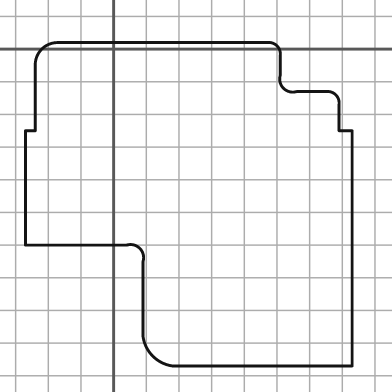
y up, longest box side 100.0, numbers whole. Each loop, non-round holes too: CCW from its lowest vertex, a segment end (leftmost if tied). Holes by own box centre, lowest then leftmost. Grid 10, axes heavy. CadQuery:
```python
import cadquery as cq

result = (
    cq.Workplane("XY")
    .moveTo(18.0, -97.0)
    .lineTo(73.0, -97.0)
    .lineTo(73.0, -25.0)
    .lineTo(69.0, -25.0)
    .lineTo(69.0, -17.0)
    .threePointArc((68.0, -14.0), (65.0, -13.0))
    .lineTo(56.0, -13.0)
    .threePointArc((52.0, -12.0), (51.0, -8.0))
    .lineTo(51.0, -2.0)
    .threePointArc((50.0, 1.0), (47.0, 2.0))
    .lineTo(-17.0, 2.0)
    .threePointArc((-22.0, 0.0), (-24.0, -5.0))
    .lineTo(-24.0, -25.0)
    .lineTo(-27.0, -25.0)
    .lineTo(-27.0, -60.0)
    .lineTo(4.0, -60.0)
    .threePointArc((8.0, -61.0), (9.0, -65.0))
    .lineTo(9.0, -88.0)
    .threePointArc((12.0, -94.0), (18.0, -97.0))
    .close()
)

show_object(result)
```